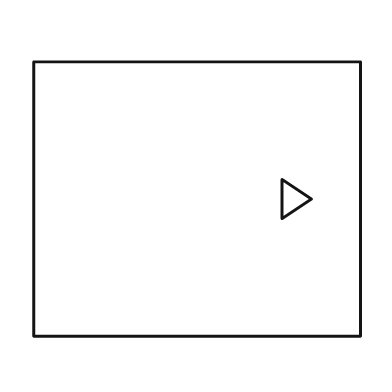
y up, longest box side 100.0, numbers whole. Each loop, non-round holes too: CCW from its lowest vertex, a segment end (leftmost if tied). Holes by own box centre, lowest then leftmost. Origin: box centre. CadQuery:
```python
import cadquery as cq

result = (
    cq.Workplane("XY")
    .moveTo(-50.0, -42.0)
    .lineTo(50.0, -42.0)
    .lineTo(50.0, 42.0)
    .lineTo(-50.0, 42.0)
    .close()
    .moveTo(26.0, -6.0)
    .lineTo(35.0, 0.0)
    .lineTo(26.0, 6.0)
    .close()
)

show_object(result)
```